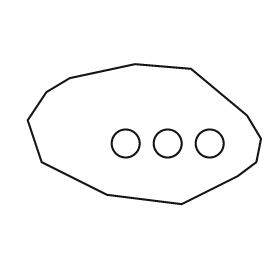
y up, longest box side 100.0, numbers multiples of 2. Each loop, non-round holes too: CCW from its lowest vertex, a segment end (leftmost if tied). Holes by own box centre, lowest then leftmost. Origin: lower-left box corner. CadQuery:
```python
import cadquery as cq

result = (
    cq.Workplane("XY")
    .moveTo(66.0, 0.0)
    .lineTo(90.0, 12.0)
    .lineTo(98.0, 18.0)
    .lineTo(100.0, 28.0)
    .lineTo(94.0, 38.0)
    .lineTo(70.0, 58.0)
    .lineTo(46.0, 60.0)
    .lineTo(18.0, 54.0)
    .lineTo(8.0, 48.0)
    .lineTo(0.0, 36.0)
    .lineTo(6.0, 18.0)
    .lineTo(34.0, 4.0)
    .close()
    .moveTo(42.0, 26.0)
    .circle(6.0)
    .moveTo(60.0, 26.0)
    .circle(6.0)
    .moveTo(78.0, 26.0)
    .circle(6.0)
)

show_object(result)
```